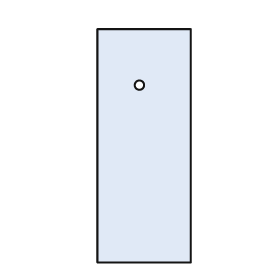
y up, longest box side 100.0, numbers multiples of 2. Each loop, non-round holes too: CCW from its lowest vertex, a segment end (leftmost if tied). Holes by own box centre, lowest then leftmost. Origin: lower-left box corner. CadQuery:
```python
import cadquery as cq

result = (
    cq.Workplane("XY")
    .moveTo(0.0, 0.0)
    .lineTo(40.0, 0.0)
    .lineTo(40.0, 100.0)
    .lineTo(0.0, 100.0)
    .close()
    .moveTo(18.0, 76.0)
    .circle(2.0)
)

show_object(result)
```